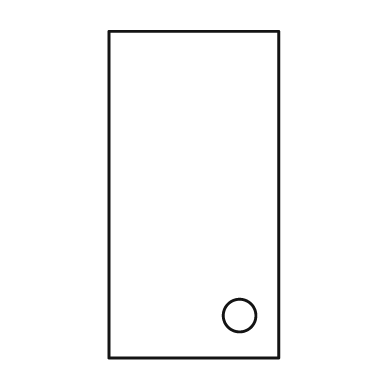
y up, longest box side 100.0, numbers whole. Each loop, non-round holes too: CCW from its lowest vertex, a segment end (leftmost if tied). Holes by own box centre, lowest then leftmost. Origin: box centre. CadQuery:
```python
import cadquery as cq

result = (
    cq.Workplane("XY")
    .moveTo(-26.0, -50.0)
    .lineTo(26.0, -50.0)
    .lineTo(26.0, 50.0)
    .lineTo(-26.0, 50.0)
    .close()
    .moveTo(14.0, -37.0)
    .circle(5.0)
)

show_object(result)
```